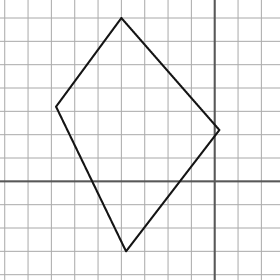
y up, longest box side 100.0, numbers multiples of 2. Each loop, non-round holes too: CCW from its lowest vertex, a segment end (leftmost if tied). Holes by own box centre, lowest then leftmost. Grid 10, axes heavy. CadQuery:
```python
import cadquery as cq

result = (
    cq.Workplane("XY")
    .moveTo(-38.0, -30.0)
    .lineTo(2.0, 22.0)
    .lineTo(-40.0, 70.0)
    .lineTo(-68.0, 32.0)
    .close()
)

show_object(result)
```